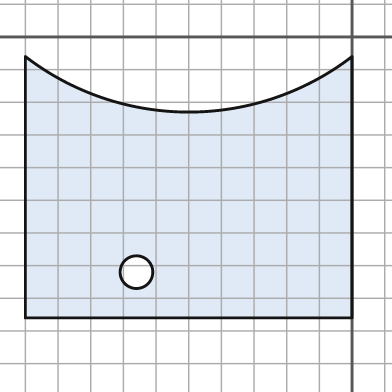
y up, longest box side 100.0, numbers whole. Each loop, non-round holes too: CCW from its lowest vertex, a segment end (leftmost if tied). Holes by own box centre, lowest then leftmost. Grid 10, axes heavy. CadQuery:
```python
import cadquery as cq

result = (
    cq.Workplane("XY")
    .moveTo(-100.0, -86.0)
    .lineTo(0.0, -86.0)
    .lineTo(0.0, -6.0)
    .threePointArc((-50.0, -23.0), (-100.0, -6.0))
    .close()
    .moveTo(-66.0, -72.0)
    .circle(5.0)
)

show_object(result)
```